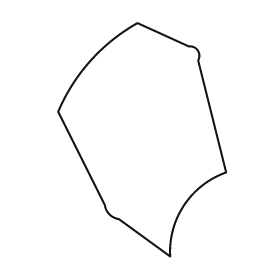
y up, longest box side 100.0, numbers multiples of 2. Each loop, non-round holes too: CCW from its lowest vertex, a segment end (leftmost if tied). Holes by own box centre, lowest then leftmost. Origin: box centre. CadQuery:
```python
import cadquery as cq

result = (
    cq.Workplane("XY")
    .moveTo(12.0, -50.0)
    .threePointArc((18.0, -28.0), (36.0, -14.0))
    .lineTo(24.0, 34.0)
    .threePointArc((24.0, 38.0), (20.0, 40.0))
    .lineTo(-2.0, 50.0)
    .threePointArc((-22.0, 34.0), (-36.0, 12.0))
    .lineTo(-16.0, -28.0)
    .threePointArc((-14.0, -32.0), (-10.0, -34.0))
    .close()
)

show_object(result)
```